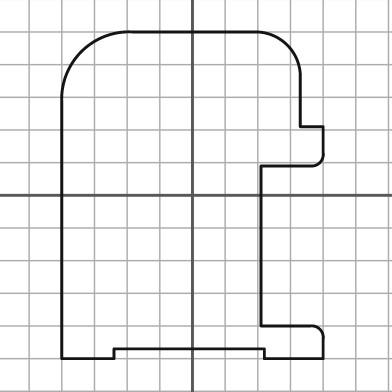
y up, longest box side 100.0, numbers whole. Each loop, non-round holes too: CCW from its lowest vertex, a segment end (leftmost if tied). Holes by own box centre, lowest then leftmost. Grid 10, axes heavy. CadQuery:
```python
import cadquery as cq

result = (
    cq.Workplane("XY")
    .moveTo(-40.0, -50.0)
    .lineTo(-24.0, -50.0)
    .lineTo(-24.0, -47.0)
    .lineTo(22.0, -47.0)
    .lineTo(22.0, -50.0)
    .lineTo(40.0, -50.0)
    .lineTo(40.0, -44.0)
    .threePointArc((39.0, -41.0), (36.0, -40.0))
    .lineTo(21.0, -40.0)
    .lineTo(21.0, 9.0)
    .lineTo(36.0, 9.0)
    .threePointArc((39.0, 10.0), (40.0, 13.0))
    .lineTo(40.0, 21.0)
    .lineTo(33.0, 21.0)
    .lineTo(33.0, 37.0)
    .threePointArc((29.0, 46.0), (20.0, 50.0))
    .lineTo(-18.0, 50.0)
    .threePointArc((-34.0, 44.0), (-40.0, 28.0))
    .close()
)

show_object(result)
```